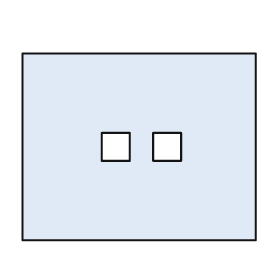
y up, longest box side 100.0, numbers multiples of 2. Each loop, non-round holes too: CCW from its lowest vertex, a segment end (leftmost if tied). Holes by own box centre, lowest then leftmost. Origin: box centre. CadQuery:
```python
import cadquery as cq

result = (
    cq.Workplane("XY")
    .moveTo(-50.0, -40.0)
    .lineTo(50.0, -40.0)
    .lineTo(50.0, 40.0)
    .lineTo(-50.0, 40.0)
    .close()
    .moveTo(-16.0, -6.0)
    .lineTo(-4.0, -6.0)
    .lineTo(-4.0, 6.0)
    .lineTo(-16.0, 6.0)
    .close()
    .moveTo(6.0, -6.0)
    .lineTo(18.0, -6.0)
    .lineTo(18.0, 6.0)
    .lineTo(6.0, 6.0)
    .close()
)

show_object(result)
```